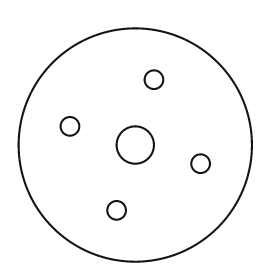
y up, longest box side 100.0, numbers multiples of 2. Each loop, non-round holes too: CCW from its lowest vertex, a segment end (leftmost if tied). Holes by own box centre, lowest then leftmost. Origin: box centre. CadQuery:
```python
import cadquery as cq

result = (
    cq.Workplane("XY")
    .moveTo(0.0, 0.0)
    .circle(50.0)
    .moveTo(-8.0, -28.0)
    .circle(4.0)
    .moveTo(28.0, -8.0)
    .circle(4.0)
    .moveTo(0.0, 0.0)
    .circle(8.0)
    .moveTo(-28.0, 8.0)
    .circle(4.0)
    .moveTo(8.0, 28.0)
    .circle(4.0)
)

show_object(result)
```